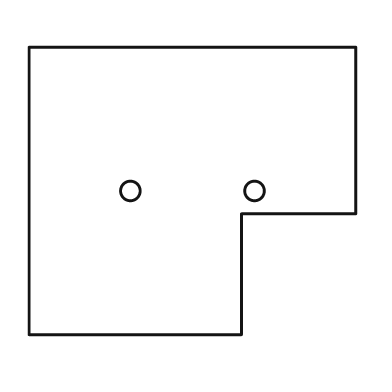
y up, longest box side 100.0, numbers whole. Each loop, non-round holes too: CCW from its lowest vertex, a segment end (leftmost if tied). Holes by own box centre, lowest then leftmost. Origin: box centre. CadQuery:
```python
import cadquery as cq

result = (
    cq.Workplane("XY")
    .moveTo(-50.0, -44.0)
    .lineTo(15.0, -44.0)
    .lineTo(15.0, -7.0)
    .lineTo(50.0, -7.0)
    .lineTo(50.0, 44.0)
    .lineTo(-50.0, 44.0)
    .close()
    .moveTo(-19.0, 0.0)
    .circle(3.0)
    .moveTo(19.0, 0.0)
    .circle(3.0)
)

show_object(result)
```